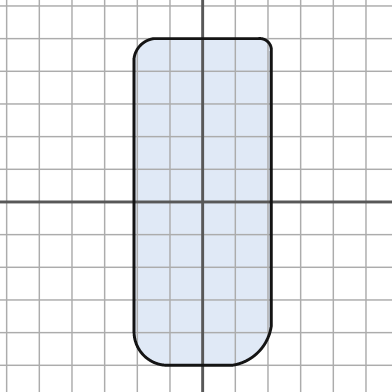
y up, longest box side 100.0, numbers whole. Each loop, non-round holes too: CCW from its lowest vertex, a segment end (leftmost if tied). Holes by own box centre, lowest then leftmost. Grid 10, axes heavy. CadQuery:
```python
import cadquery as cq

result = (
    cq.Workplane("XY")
    .moveTo(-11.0, -50.0)
    .lineTo(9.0, -50.0)
    .threePointArc((17.0, -46.0), (21.0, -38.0))
    .lineTo(21.0, 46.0)
    .threePointArc((20.0, 49.0), (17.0, 50.0))
    .lineTo(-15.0, 50.0)
    .threePointArc((-19.0, 48.0), (-21.0, 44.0))
    .lineTo(-21.0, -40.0)
    .threePointArc((-18.0, -47.0), (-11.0, -50.0))
    .close()
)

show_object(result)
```